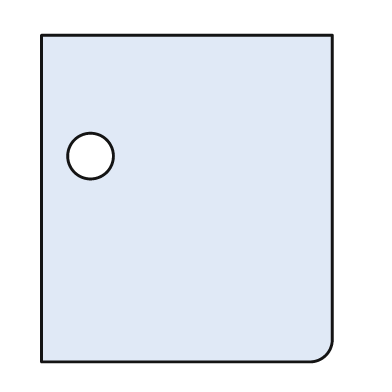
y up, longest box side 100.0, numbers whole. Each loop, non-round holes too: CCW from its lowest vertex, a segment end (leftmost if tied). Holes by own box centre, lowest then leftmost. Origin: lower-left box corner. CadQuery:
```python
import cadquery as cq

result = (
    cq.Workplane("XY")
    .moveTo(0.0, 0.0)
    .lineTo(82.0, 0.0)
    .threePointArc((87.0, 2.0), (89.0, 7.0))
    .lineTo(89.0, 100.0)
    .lineTo(0.0, 100.0)
    .close()
    .moveTo(15.0, 63.0)
    .circle(7.0)
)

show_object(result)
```